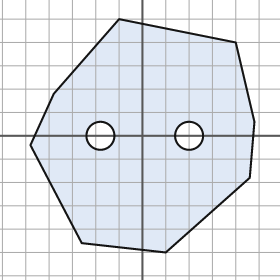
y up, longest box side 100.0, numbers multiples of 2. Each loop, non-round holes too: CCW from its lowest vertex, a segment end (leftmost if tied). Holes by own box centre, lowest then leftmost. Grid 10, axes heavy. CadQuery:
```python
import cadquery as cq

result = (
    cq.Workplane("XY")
    .moveTo(10.0, -50.0)
    .lineTo(46.0, -18.0)
    .lineTo(48.0, 6.0)
    .lineTo(40.0, 40.0)
    .lineTo(-10.0, 50.0)
    .lineTo(-38.0, 18.0)
    .lineTo(-48.0, -4.0)
    .lineTo(-26.0, -46.0)
    .close()
    .moveTo(-18.0, 0.0)
    .circle(6.0)
    .moveTo(20.0, 0.0)
    .circle(6.0)
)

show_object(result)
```